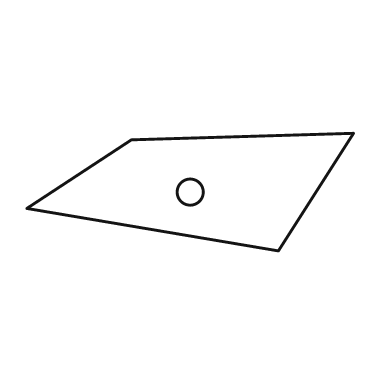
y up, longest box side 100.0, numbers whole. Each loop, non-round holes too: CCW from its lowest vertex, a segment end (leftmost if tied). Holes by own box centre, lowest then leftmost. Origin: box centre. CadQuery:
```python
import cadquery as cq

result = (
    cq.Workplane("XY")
    .moveTo(27.0, -18.0)
    .lineTo(50.0, 18.0)
    .lineTo(-18.0, 16.0)
    .lineTo(-50.0, -5.0)
    .close()
    .moveTo(0.0, 0.0)
    .circle(4.0)
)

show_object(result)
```